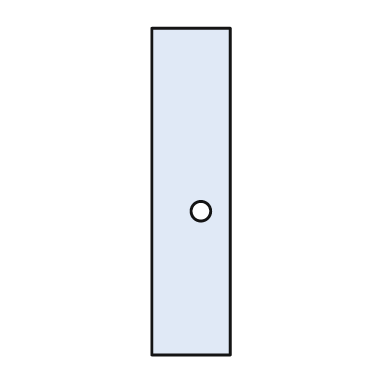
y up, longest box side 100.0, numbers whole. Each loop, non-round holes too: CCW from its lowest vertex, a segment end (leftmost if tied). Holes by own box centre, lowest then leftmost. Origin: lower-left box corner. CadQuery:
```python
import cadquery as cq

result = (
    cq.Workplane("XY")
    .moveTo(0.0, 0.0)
    .lineTo(24.0, 0.0)
    .lineTo(24.0, 100.0)
    .lineTo(0.0, 100.0)
    .close()
    .moveTo(15.0, 44.0)
    .circle(3.0)
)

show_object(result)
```